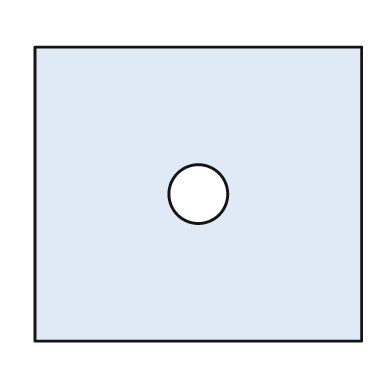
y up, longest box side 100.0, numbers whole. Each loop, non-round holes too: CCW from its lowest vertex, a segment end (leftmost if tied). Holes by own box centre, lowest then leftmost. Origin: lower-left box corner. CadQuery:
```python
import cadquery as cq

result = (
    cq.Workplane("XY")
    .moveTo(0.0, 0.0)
    .lineTo(100.0, 0.0)
    .lineTo(100.0, 90.0)
    .lineTo(0.0, 90.0)
    .close()
    .moveTo(50.0, 45.0)
    .circle(9.0)
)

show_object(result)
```